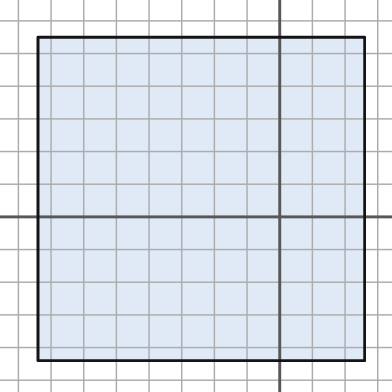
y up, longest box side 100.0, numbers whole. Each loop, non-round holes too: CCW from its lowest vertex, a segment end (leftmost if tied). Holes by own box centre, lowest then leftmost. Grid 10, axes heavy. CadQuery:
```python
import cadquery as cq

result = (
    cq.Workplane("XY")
    .moveTo(-74.0, -44.0)
    .lineTo(26.0, -44.0)
    .lineTo(26.0, 55.0)
    .lineTo(-74.0, 55.0)
    .close()
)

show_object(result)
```